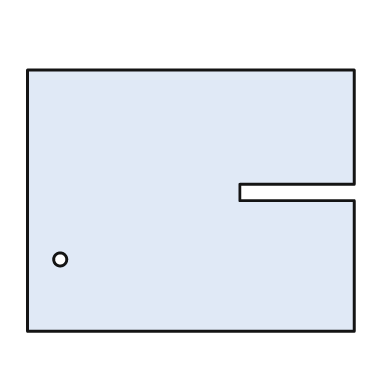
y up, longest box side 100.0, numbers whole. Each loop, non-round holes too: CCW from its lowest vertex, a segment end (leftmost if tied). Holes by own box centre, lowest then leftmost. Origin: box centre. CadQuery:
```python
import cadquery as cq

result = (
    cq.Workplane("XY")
    .moveTo(-50.0, -40.0)
    .lineTo(50.0, -40.0)
    .lineTo(50.0, 0.0)
    .lineTo(15.0, 0.0)
    .lineTo(15.0, 5.0)
    .lineTo(50.0, 5.0)
    .lineTo(50.0, 40.0)
    .lineTo(-50.0, 40.0)
    .close()
    .moveTo(-40.0, -18.0)
    .circle(2.0)
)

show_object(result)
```